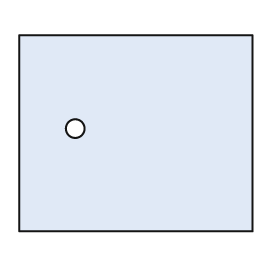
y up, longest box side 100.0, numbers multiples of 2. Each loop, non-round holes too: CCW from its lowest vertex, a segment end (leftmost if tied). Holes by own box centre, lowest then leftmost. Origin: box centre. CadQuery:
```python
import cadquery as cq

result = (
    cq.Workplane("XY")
    .moveTo(-50.0, -42.0)
    .lineTo(50.0, -42.0)
    .lineTo(50.0, 42.0)
    .lineTo(-50.0, 42.0)
    .close()
    .moveTo(-26.0, 2.0)
    .circle(4.0)
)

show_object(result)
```